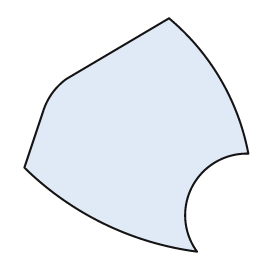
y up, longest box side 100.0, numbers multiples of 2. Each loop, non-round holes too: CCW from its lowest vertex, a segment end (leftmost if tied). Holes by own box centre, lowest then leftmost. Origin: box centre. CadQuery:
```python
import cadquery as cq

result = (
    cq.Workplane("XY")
    .moveTo(26.0, -50.0)
    .threePointArc((24.0, -22.0), (48.0, -8.0))
    .threePointArc((36.0, 24.0), (14.0, 50.0))
    .lineTo(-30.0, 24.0)
    .threePointArc((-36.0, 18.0), (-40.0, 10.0))
    .lineTo(-48.0, -14.0)
    .threePointArc((-14.0, -38.0), (26.0, -50.0))
    .close()
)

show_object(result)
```